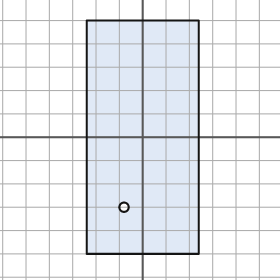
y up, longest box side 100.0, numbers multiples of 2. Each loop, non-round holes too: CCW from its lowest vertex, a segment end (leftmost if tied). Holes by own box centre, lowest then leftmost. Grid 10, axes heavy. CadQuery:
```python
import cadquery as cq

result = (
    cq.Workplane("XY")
    .moveTo(-24.0, -50.0)
    .lineTo(24.0, -50.0)
    .lineTo(24.0, 50.0)
    .lineTo(-24.0, 50.0)
    .close()
    .moveTo(-8.0, -30.0)
    .circle(2.0)
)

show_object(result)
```